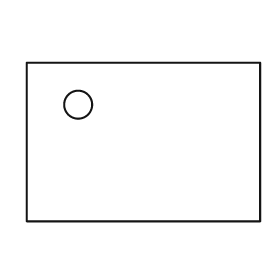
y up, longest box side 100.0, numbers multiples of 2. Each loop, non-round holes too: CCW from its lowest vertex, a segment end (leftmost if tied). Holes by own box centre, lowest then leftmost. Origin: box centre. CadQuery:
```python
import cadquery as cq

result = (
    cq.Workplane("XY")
    .moveTo(-50.0, -34.0)
    .lineTo(50.0, -34.0)
    .lineTo(50.0, 34.0)
    .lineTo(-50.0, 34.0)
    .close()
    .moveTo(-28.0, 16.0)
    .circle(6.0)
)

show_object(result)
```